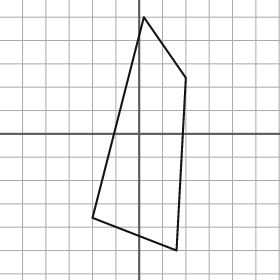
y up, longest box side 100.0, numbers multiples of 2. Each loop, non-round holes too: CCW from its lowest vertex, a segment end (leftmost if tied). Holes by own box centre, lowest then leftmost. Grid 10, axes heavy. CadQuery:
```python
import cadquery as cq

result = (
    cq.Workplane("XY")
    .moveTo(16.0, -50.0)
    .lineTo(20.0, 24.0)
    .lineTo(2.0, 50.0)
    .lineTo(-20.0, -36.0)
    .close()
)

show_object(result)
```